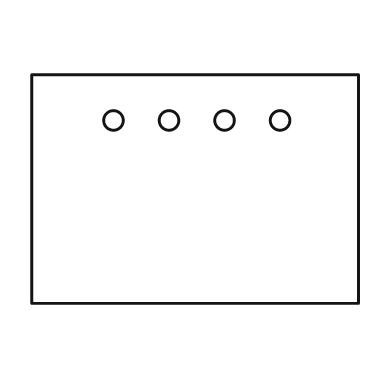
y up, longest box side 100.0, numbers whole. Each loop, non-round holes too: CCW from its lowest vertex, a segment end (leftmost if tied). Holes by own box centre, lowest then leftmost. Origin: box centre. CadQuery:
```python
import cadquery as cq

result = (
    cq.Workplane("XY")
    .moveTo(-50.0, -35.0)
    .lineTo(50.0, -35.0)
    .lineTo(50.0, 35.0)
    .lineTo(-50.0, 35.0)
    .close()
    .moveTo(-25.0, 21.0)
    .circle(3.0)
    .moveTo(-8.0, 21.0)
    .circle(3.0)
    .moveTo(9.0, 21.0)
    .circle(3.0)
    .moveTo(26.0, 21.0)
    .circle(3.0)
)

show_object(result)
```